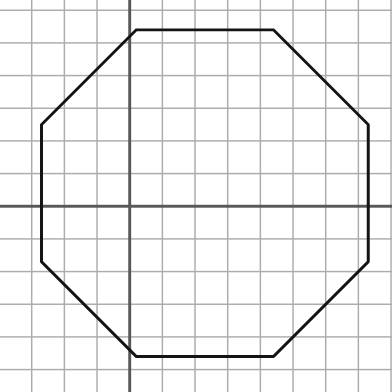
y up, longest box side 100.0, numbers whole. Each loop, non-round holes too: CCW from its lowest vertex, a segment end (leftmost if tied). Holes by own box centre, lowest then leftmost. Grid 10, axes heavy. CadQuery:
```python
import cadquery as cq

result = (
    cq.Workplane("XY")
    .moveTo(2.0, -46.0)
    .lineTo(44.0, -46.0)
    .lineTo(73.0, -17.0)
    .lineTo(73.0, 25.0)
    .lineTo(44.0, 54.0)
    .lineTo(2.0, 54.0)
    .lineTo(-27.0, 25.0)
    .lineTo(-27.0, -17.0)
    .close()
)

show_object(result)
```